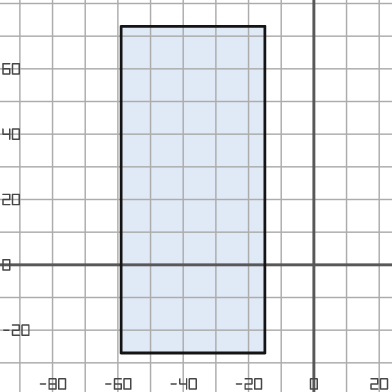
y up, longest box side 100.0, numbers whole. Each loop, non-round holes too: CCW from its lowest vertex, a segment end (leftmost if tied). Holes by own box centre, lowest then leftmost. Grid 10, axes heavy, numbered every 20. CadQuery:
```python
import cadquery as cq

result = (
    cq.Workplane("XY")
    .moveTo(-59.0, -27.0)
    .lineTo(-15.0, -27.0)
    .lineTo(-15.0, 73.0)
    .lineTo(-59.0, 73.0)
    .close()
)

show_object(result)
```